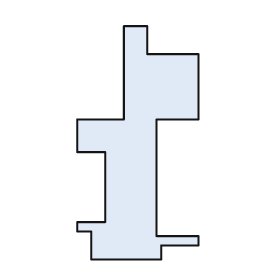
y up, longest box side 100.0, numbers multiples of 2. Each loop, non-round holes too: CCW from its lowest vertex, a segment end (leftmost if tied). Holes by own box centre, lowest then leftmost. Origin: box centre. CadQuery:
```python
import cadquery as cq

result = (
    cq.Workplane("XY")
    .moveTo(-20.0, -50.0)
    .lineTo(10.0, -50.0)
    .lineTo(10.0, -44.0)
    .lineTo(26.0, -44.0)
    .lineTo(26.0, -40.0)
    .lineTo(8.0, -40.0)
    .lineTo(8.0, 10.0)
    .lineTo(26.0, 10.0)
    .lineTo(26.0, 38.0)
    .lineTo(4.0, 38.0)
    .lineTo(4.0, 50.0)
    .lineTo(-6.0, 50.0)
    .lineTo(-6.0, 10.0)
    .lineTo(-26.0, 10.0)
    .lineTo(-26.0, -4.0)
    .lineTo(-14.0, -4.0)
    .lineTo(-14.0, -34.0)
    .lineTo(-26.0, -34.0)
    .lineTo(-26.0, -38.0)
    .lineTo(-20.0, -38.0)
    .close()
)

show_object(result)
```